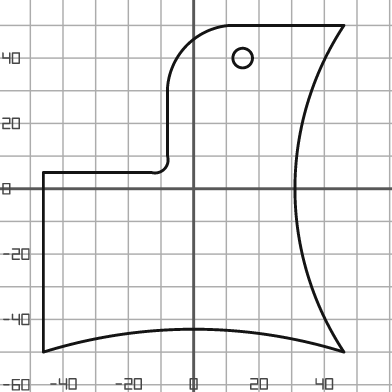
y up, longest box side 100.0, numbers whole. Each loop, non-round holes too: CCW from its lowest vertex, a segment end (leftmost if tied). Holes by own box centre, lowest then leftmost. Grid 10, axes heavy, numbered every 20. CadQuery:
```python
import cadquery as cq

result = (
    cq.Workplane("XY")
    .moveTo(-46.0, -50.0)
    .threePointArc((0.0, -43.0), (46.0, -50.0))
    .threePointArc((31.0, 0.0), (46.0, 50.0))
    .lineTo(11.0, 50.0)
    .threePointArc((-2.0, 44.0), (-8.0, 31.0))
    .lineTo(-8.0, 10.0)
    .threePointArc((-9.0, 6.0), (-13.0, 5.0))
    .lineTo(-46.0, 5.0)
    .close()
    .moveTo(15.0, 40.0)
    .circle(3.0)
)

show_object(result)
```